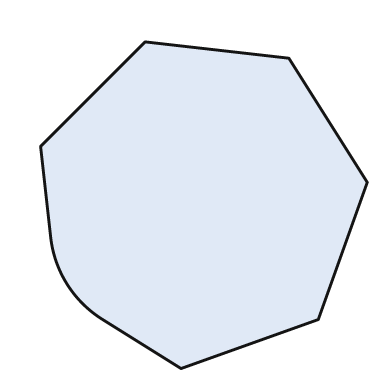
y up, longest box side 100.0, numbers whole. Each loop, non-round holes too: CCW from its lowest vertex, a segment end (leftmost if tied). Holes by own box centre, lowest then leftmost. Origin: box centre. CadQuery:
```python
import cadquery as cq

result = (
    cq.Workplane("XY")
    .moveTo(-7.0, -50.0)
    .lineTo(35.0, -35.0)
    .lineTo(50.0, 7.0)
    .lineTo(26.0, 45.0)
    .lineTo(-18.0, 50.0)
    .lineTo(-50.0, 18.0)
    .lineTo(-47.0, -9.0)
    .threePointArc((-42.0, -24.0), (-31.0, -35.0))
    .close()
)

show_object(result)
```